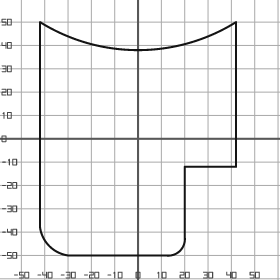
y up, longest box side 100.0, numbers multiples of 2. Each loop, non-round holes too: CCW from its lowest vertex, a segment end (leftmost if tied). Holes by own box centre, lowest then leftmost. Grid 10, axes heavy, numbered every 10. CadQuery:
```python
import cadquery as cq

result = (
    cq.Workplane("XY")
    .moveTo(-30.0, -50.0)
    .lineTo(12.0, -50.0)
    .threePointArc((18.0, -48.0), (20.0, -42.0))
    .lineTo(20.0, -12.0)
    .lineTo(42.0, -12.0)
    .lineTo(42.0, 50.0)
    .threePointArc((0.0, 38.0), (-42.0, 50.0))
    .lineTo(-42.0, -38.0)
    .threePointArc((-38.0, -46.0), (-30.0, -50.0))
    .close()
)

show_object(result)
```